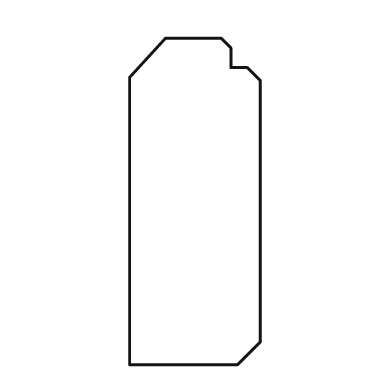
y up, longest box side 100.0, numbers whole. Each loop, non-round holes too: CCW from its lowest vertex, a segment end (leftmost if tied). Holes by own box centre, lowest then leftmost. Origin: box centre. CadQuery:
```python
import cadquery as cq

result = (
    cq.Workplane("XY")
    .moveTo(-20.0, -50.0)
    .lineTo(13.0, -50.0)
    .lineTo(20.0, -43.0)
    .lineTo(20.0, 37.0)
    .lineTo(16.0, 41.0)
    .lineTo(11.0, 41.0)
    .lineTo(11.0, 47.0)
    .lineTo(8.0, 50.0)
    .lineTo(-9.0, 50.0)
    .lineTo(-20.0, 38.0)
    .close()
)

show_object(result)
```